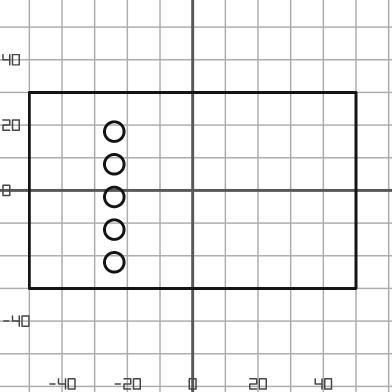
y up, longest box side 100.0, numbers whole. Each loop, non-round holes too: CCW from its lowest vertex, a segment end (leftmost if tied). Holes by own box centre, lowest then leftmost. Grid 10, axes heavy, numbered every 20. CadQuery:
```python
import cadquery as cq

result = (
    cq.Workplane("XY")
    .moveTo(-50.0, -30.0)
    .lineTo(50.0, -30.0)
    .lineTo(50.0, 30.0)
    .lineTo(-50.0, 30.0)
    .close()
    .moveTo(-24.0, -22.0)
    .circle(3.0)
    .moveTo(-24.0, -12.0)
    .circle(3.0)
    .moveTo(-24.0, -2.0)
    .circle(3.0)
    .moveTo(-24.0, 8.0)
    .circle(3.0)
    .moveTo(-24.0, 18.0)
    .circle(3.0)
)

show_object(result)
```